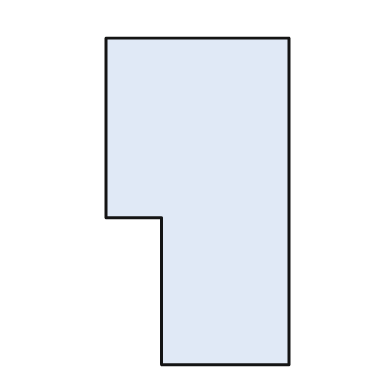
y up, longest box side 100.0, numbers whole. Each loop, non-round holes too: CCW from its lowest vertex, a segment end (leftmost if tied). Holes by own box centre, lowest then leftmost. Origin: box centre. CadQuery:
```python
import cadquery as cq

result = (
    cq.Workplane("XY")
    .moveTo(-11.0, -50.0)
    .lineTo(28.0, -50.0)
    .lineTo(28.0, 50.0)
    .lineTo(-28.0, 50.0)
    .lineTo(-28.0, -5.0)
    .lineTo(-11.0, -5.0)
    .close()
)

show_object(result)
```